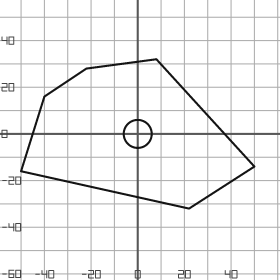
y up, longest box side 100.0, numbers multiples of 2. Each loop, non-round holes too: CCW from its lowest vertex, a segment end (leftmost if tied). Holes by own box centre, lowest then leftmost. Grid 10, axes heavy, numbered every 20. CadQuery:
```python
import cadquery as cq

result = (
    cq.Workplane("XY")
    .moveTo(22.0, -32.0)
    .lineTo(50.0, -14.0)
    .lineTo(8.0, 32.0)
    .lineTo(-22.0, 28.0)
    .lineTo(-40.0, 16.0)
    .lineTo(-50.0, -16.0)
    .close()
    .moveTo(0.0, 0.0)
    .circle(6.0)
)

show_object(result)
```